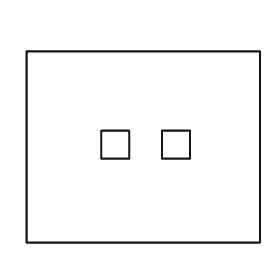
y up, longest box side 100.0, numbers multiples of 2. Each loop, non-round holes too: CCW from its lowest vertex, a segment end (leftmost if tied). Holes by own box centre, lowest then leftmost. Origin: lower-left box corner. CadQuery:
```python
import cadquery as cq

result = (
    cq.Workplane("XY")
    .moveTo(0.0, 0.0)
    .lineTo(100.0, 0.0)
    .lineTo(100.0, 82.0)
    .lineTo(0.0, 82.0)
    .close()
    .moveTo(32.0, 36.0)
    .lineTo(44.0, 36.0)
    .lineTo(44.0, 48.0)
    .lineTo(32.0, 48.0)
    .close()
    .moveTo(58.0, 36.0)
    .lineTo(70.0, 36.0)
    .lineTo(70.0, 48.0)
    .lineTo(58.0, 48.0)
    .close()
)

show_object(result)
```